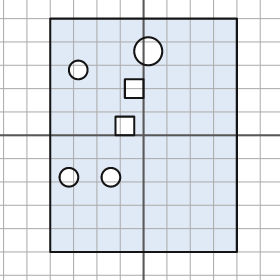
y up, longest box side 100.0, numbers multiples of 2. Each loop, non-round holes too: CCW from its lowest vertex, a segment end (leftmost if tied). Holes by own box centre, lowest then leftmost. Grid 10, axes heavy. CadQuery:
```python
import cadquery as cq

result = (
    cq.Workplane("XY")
    .moveTo(-40.0, -50.0)
    .lineTo(40.0, -50.0)
    .lineTo(40.0, 50.0)
    .lineTo(-40.0, 50.0)
    .close()
    .moveTo(-32.0, -18.0)
    .circle(4.0)
    .moveTo(-14.0, -18.0)
    .circle(4.0)
    .moveTo(-12.0, 0.0)
    .lineTo(-4.0, 0.0)
    .lineTo(-4.0, 8.0)
    .lineTo(-12.0, 8.0)
    .close()
    .moveTo(-8.0, 16.0)
    .lineTo(0.0, 16.0)
    .lineTo(0.0, 24.0)
    .lineTo(-8.0, 24.0)
    .close()
    .moveTo(-28.0, 28.0)
    .circle(4.0)
    .moveTo(2.0, 36.0)
    .circle(6.0)
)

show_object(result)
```